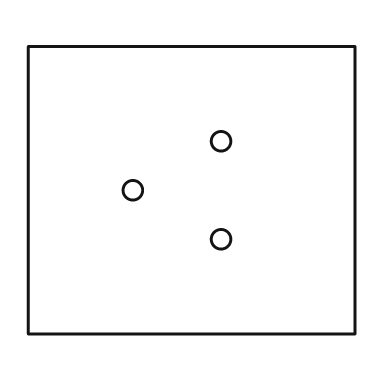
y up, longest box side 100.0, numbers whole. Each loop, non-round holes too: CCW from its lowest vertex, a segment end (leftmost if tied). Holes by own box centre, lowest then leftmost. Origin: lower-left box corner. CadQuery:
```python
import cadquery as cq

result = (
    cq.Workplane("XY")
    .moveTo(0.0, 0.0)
    .lineTo(100.0, 0.0)
    .lineTo(100.0, 88.0)
    .lineTo(0.0, 88.0)
    .close()
    .moveTo(59.0, 29.0)
    .circle(3.0)
    .moveTo(32.0, 44.0)
    .circle(3.0)
    .moveTo(59.0, 59.0)
    .circle(3.0)
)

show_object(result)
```